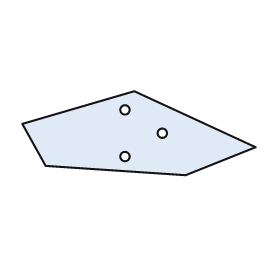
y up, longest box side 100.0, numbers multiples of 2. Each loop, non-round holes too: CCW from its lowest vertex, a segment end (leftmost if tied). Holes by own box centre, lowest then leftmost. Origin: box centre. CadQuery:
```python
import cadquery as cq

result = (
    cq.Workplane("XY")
    .moveTo(20.0, -18.0)
    .lineTo(50.0, -6.0)
    .lineTo(-2.0, 18.0)
    .lineTo(-50.0, 4.0)
    .lineTo(-40.0, -14.0)
    .close()
    .moveTo(-6.0, -10.0)
    .circle(2.0)
    .moveTo(10.0, 0.0)
    .circle(2.0)
    .moveTo(-6.0, 10.0)
    .circle(2.0)
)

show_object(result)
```